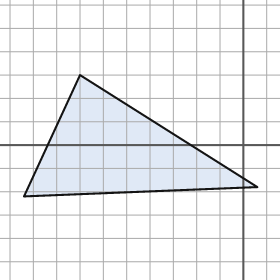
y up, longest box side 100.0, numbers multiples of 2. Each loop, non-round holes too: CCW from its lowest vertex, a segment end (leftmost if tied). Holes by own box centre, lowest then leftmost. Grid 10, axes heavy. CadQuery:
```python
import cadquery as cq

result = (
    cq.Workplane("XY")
    .moveTo(-94.0, -22.0)
    .lineTo(6.0, -18.0)
    .lineTo(-70.0, 30.0)
    .close()
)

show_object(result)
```